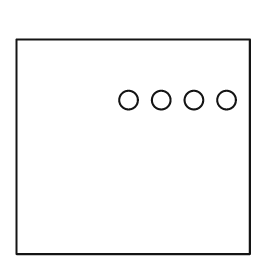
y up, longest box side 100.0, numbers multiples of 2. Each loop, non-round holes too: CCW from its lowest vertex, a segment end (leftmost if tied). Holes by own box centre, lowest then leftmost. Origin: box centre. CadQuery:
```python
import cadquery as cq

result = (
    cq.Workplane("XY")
    .moveTo(-50.0, -46.0)
    .lineTo(50.0, -46.0)
    .lineTo(50.0, 46.0)
    .lineTo(-50.0, 46.0)
    .close()
    .moveTo(-2.0, 20.0)
    .circle(4.0)
    .moveTo(12.0, 20.0)
    .circle(4.0)
    .moveTo(26.0, 20.0)
    .circle(4.0)
    .moveTo(40.0, 20.0)
    .circle(4.0)
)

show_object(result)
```